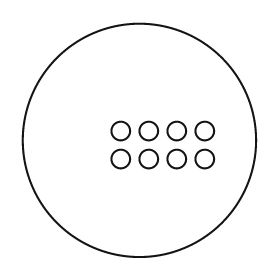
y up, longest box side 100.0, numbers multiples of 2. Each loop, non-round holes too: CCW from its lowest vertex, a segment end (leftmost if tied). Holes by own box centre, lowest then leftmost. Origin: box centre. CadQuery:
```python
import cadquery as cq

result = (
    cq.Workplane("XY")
    .moveTo(0.0, 0.0)
    .circle(50.0)
    .moveTo(-8.0, -8.0)
    .circle(4.0)
    .moveTo(4.0, -8.0)
    .circle(4.0)
    .moveTo(16.0, -8.0)
    .circle(4.0)
    .moveTo(28.0, -8.0)
    .circle(4.0)
    .moveTo(-8.0, 4.0)
    .circle(4.0)
    .moveTo(4.0, 4.0)
    .circle(4.0)
    .moveTo(16.0, 4.0)
    .circle(4.0)
    .moveTo(28.0, 4.0)
    .circle(4.0)
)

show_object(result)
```